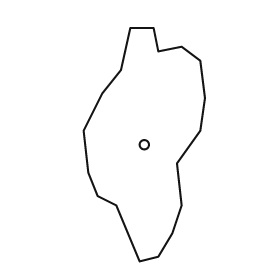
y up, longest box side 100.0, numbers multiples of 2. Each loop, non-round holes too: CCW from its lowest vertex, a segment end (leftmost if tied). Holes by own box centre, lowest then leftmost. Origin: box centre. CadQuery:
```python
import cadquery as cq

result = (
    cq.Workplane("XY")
    .moveTo(-2.0, -50.0)
    .lineTo(6.0, -48.0)
    .lineTo(12.0, -38.0)
    .lineTo(16.0, -26.0)
    .lineTo(14.0, -8.0)
    .lineTo(24.0, 6.0)
    .lineTo(26.0, 20.0)
    .lineTo(24.0, 36.0)
    .lineTo(16.0, 42.0)
    .lineTo(6.0, 40.0)
    .lineTo(4.0, 50.0)
    .lineTo(-6.0, 50.0)
    .lineTo(-10.0, 32.0)
    .lineTo(-18.0, 22.0)
    .lineTo(-26.0, 6.0)
    .lineTo(-24.0, -12.0)
    .lineTo(-20.0, -22.0)
    .lineTo(-12.0, -26.0)
    .close()
    .moveTo(0.0, 0.0)
    .circle(2.0)
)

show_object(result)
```